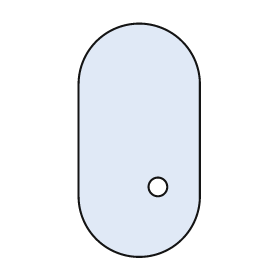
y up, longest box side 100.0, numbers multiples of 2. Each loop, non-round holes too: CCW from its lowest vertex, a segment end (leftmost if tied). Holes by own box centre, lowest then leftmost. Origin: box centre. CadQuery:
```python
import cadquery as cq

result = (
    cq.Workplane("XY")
    .moveTo(-26.0, -24.0)
    .threePointArc((0.0, -50.0), (26.0, -24.0))
    .lineTo(26.0, 24.0)
    .threePointArc((0.0, 50.0), (-26.0, 24.0))
    .close()
    .moveTo(8.0, -20.0)
    .circle(4.0)
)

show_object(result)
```